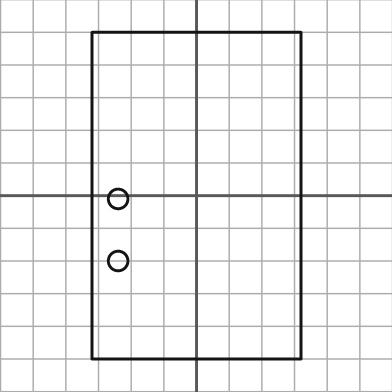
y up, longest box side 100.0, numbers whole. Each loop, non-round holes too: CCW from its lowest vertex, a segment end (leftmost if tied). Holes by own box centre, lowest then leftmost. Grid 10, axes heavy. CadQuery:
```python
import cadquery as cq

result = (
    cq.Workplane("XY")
    .moveTo(-32.0, -50.0)
    .lineTo(32.0, -50.0)
    .lineTo(32.0, 50.0)
    .lineTo(-32.0, 50.0)
    .close()
    .moveTo(-24.0, -20.0)
    .circle(3.0)
    .moveTo(-24.0, -1.0)
    .circle(3.0)
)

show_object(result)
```